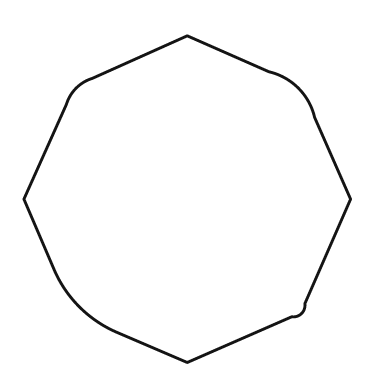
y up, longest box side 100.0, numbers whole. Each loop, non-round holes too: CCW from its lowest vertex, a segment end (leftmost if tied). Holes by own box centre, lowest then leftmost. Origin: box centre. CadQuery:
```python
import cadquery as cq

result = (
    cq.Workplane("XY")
    .moveTo(0.0, -50.0)
    .lineTo(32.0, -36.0)
    .threePointArc((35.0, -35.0), (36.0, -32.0))
    .lineTo(50.0, 0.0)
    .lineTo(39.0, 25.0)
    .threePointArc((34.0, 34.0), (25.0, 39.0))
    .lineTo(0.0, 50.0)
    .lineTo(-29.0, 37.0)
    .threePointArc((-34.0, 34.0), (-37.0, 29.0))
    .lineTo(-50.0, 0.0)
    .lineTo(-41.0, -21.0)
    .threePointArc((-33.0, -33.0), (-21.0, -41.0))
    .close()
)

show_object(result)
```